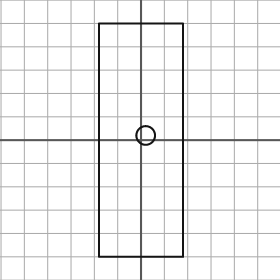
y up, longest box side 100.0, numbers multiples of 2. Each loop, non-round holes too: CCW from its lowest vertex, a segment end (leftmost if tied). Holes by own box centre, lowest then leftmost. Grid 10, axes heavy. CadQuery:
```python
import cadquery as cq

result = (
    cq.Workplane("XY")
    .moveTo(-18.0, -50.0)
    .lineTo(18.0, -50.0)
    .lineTo(18.0, 50.0)
    .lineTo(-18.0, 50.0)
    .close()
    .moveTo(2.0, 2.0)
    .circle(4.0)
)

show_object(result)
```